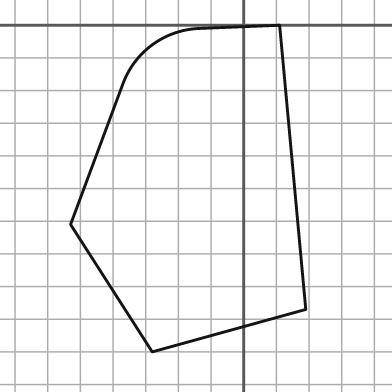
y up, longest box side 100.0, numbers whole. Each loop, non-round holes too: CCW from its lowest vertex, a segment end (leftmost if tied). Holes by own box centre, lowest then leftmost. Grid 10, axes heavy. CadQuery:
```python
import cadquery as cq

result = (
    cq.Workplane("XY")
    .moveTo(-28.0, -100.0)
    .lineTo(19.0, -87.0)
    .lineTo(11.0, 0.0)
    .lineTo(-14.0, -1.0)
    .threePointArc((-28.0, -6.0), (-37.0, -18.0))
    .lineTo(-53.0, -61.0)
    .close()
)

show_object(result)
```